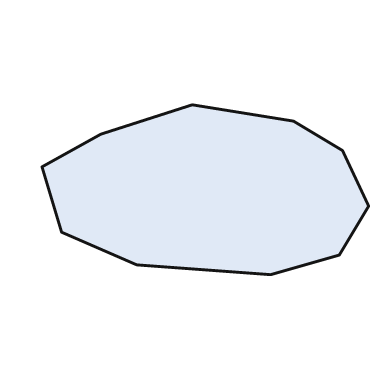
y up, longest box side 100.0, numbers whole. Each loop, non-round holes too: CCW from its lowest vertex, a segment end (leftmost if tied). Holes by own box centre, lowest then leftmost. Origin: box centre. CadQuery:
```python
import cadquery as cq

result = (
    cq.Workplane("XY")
    .moveTo(20.0, -26.0)
    .lineTo(41.0, -20.0)
    .lineTo(50.0, -5.0)
    .lineTo(42.0, 12.0)
    .lineTo(27.0, 21.0)
    .lineTo(-4.0, 26.0)
    .lineTo(-32.0, 17.0)
    .lineTo(-50.0, 7.0)
    .lineTo(-44.0, -13.0)
    .lineTo(-21.0, -23.0)
    .close()
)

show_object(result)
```